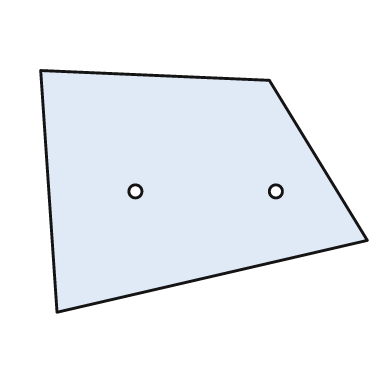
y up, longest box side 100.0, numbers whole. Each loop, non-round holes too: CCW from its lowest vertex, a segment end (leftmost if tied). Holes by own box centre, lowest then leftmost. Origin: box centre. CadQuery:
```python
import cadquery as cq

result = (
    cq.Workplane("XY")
    .moveTo(-45.0, -37.0)
    .lineTo(50.0, -15.0)
    .lineTo(20.0, 34.0)
    .lineTo(-50.0, 37.0)
    .close()
    .moveTo(-21.0, 0.0)
    .circle(2.0)
    .moveTo(22.0, 0.0)
    .circle(2.0)
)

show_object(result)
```